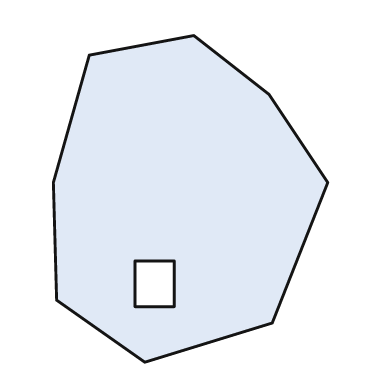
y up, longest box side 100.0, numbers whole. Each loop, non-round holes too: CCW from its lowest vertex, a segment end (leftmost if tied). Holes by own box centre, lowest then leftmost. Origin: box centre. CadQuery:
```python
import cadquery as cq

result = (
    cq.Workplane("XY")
    .moveTo(-14.0, -50.0)
    .lineTo(25.0, -38.0)
    .lineTo(42.0, 5.0)
    .lineTo(24.0, 32.0)
    .lineTo(1.0, 50.0)
    .lineTo(-31.0, 44.0)
    .lineTo(-42.0, 5.0)
    .lineTo(-41.0, -31.0)
    .close()
    .moveTo(-17.0, -33.0)
    .lineTo(-5.0, -33.0)
    .lineTo(-5.0, -19.0)
    .lineTo(-17.0, -19.0)
    .close()
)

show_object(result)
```